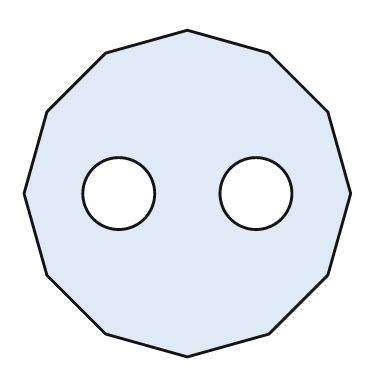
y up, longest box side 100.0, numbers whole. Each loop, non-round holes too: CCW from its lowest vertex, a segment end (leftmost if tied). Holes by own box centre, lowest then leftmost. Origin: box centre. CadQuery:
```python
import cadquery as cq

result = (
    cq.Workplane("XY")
    .moveTo(0.0, -50.0)
    .lineTo(25.0, -43.0)
    .lineTo(43.0, -25.0)
    .lineTo(50.0, 0.0)
    .lineTo(43.0, 25.0)
    .lineTo(25.0, 43.0)
    .lineTo(0.0, 50.0)
    .lineTo(-25.0, 43.0)
    .lineTo(-43.0, 25.0)
    .lineTo(-50.0, 0.0)
    .lineTo(-43.0, -25.0)
    .lineTo(-25.0, -43.0)
    .close()
    .moveTo(-21.0, 0.0)
    .circle(11.0)
    .moveTo(21.0, 0.0)
    .circle(11.0)
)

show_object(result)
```